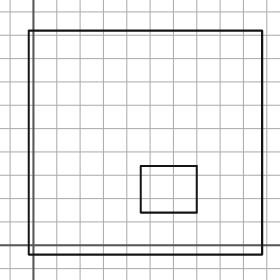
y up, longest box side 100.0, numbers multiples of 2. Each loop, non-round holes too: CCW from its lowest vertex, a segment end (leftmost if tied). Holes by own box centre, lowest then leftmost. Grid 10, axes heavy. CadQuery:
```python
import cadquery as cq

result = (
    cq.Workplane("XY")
    .moveTo(-2.0, -4.0)
    .lineTo(98.0, -4.0)
    .lineTo(98.0, 92.0)
    .lineTo(-2.0, 92.0)
    .close()
    .moveTo(46.0, 14.0)
    .lineTo(70.0, 14.0)
    .lineTo(70.0, 34.0)
    .lineTo(46.0, 34.0)
    .close()
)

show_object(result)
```